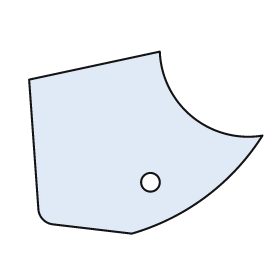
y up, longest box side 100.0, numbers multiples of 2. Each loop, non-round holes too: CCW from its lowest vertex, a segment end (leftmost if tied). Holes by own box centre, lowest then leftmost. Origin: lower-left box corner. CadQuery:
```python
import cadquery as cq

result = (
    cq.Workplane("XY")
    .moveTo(44.0, 0.0)
    .threePointArc((76.0, 16.0), (100.0, 42.0))
    .threePointArc((70.0, 50.0), (56.0, 78.0))
    .lineTo(0.0, 66.0)
    .lineTo(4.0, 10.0)
    .threePointArc((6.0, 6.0), (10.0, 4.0))
    .close()
    .moveTo(52.0, 22.0)
    .circle(4.0)
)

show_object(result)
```